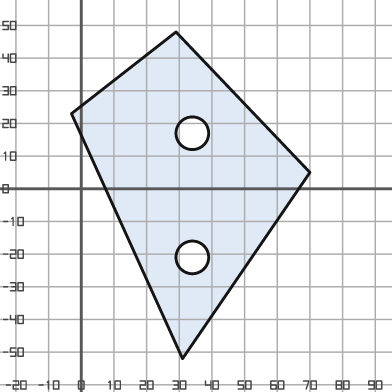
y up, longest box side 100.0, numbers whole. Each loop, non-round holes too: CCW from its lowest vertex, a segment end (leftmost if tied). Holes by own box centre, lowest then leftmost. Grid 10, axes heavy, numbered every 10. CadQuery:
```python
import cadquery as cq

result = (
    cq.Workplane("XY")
    .moveTo(31.0, -52.0)
    .lineTo(70.0, 5.0)
    .lineTo(29.0, 48.0)
    .lineTo(-3.0, 23.0)
    .close()
    .moveTo(34.0, -21.0)
    .circle(5.0)
    .moveTo(34.0, 17.0)
    .circle(5.0)
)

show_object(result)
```